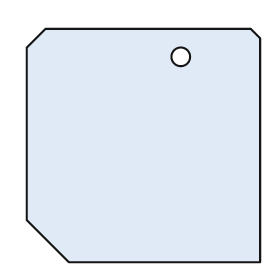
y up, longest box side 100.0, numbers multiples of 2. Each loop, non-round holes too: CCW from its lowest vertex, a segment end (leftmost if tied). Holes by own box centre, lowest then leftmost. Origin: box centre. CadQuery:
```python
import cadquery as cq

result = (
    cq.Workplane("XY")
    .moveTo(-32.0, -50.0)
    .lineTo(50.0, -50.0)
    .lineTo(50.0, 46.0)
    .lineTo(46.0, 50.0)
    .lineTo(-42.0, 50.0)
    .lineTo(-50.0, 42.0)
    .lineTo(-50.0, -32.0)
    .close()
    .moveTo(16.0, 38.0)
    .circle(4.0)
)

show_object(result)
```